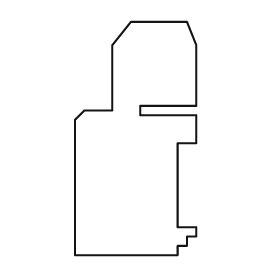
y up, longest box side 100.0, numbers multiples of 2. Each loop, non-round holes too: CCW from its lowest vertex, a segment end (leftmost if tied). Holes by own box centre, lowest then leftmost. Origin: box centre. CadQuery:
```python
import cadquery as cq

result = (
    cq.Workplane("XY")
    .moveTo(-26.0, -50.0)
    .lineTo(18.0, -50.0)
    .lineTo(18.0, -46.0)
    .lineTo(22.0, -46.0)
    .lineTo(22.0, -42.0)
    .lineTo(26.0, -42.0)
    .lineTo(26.0, -38.0)
    .lineTo(18.0, -38.0)
    .lineTo(18.0, -2.0)
    .lineTo(26.0, -2.0)
    .lineTo(26.0, 10.0)
    .lineTo(2.0, 10.0)
    .lineTo(2.0, 14.0)
    .lineTo(26.0, 14.0)
    .lineTo(26.0, 40.0)
    .lineTo(22.0, 50.0)
    .lineTo(-2.0, 50.0)
    .lineTo(-10.0, 40.0)
    .lineTo(-10.0, 12.0)
    .lineTo(-22.0, 12.0)
    .lineTo(-26.0, 8.0)
    .close()
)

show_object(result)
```